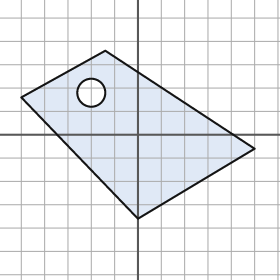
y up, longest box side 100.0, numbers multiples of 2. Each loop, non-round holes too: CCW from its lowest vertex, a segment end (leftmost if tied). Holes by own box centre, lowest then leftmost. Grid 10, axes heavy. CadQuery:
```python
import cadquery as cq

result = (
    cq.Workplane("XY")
    .moveTo(0.0, -36.0)
    .lineTo(50.0, -6.0)
    .lineTo(-14.0, 36.0)
    .lineTo(-50.0, 16.0)
    .close()
    .moveTo(-20.0, 18.0)
    .circle(6.0)
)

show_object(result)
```